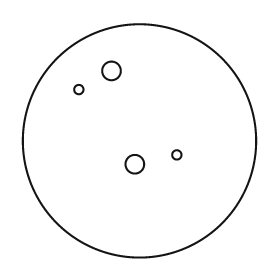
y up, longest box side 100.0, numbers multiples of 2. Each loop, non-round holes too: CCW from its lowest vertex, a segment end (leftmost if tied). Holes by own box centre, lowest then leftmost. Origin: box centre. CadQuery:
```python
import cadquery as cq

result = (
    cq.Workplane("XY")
    .moveTo(0.0, 0.0)
    .circle(50.0)
    .moveTo(-2.0, -10.0)
    .circle(4.0)
    .moveTo(16.0, -6.0)
    .circle(2.0)
    .moveTo(-26.0, 22.0)
    .circle(2.0)
    .moveTo(-12.0, 30.0)
    .circle(4.0)
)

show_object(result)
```